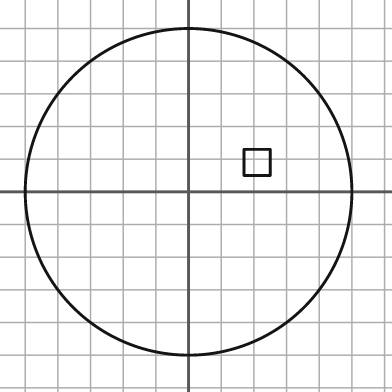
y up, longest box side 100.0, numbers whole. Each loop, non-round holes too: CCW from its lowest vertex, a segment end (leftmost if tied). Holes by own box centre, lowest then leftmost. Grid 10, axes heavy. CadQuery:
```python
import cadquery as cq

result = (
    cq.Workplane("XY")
    .moveTo(0.0, 0.0)
    .circle(50.0)
    .moveTo(17.0, 5.0)
    .lineTo(25.0, 5.0)
    .lineTo(25.0, 13.0)
    .lineTo(17.0, 13.0)
    .close()
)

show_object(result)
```